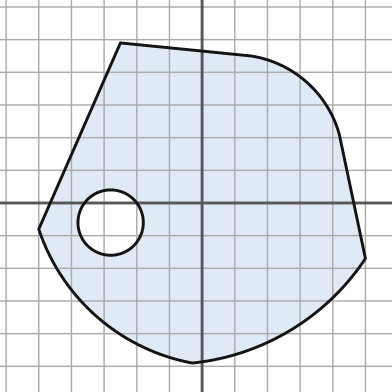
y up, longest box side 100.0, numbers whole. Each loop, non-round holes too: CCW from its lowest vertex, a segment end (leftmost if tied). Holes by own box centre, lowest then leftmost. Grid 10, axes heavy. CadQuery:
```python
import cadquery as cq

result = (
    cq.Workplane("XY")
    .moveTo(-3.0, -49.0)
    .threePointArc((27.0, -39.0), (50.0, -17.0))
    .lineTo(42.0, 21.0)
    .threePointArc((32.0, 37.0), (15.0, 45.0))
    .lineTo(-25.0, 49.0)
    .lineTo(-50.0, -8.0)
    .threePointArc((-32.0, -35.0), (-3.0, -49.0))
    .close()
    .moveTo(-28.0, -6.0)
    .circle(10.0)
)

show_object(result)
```